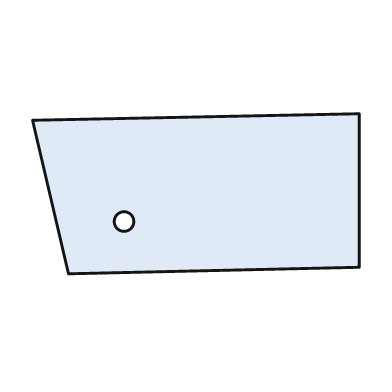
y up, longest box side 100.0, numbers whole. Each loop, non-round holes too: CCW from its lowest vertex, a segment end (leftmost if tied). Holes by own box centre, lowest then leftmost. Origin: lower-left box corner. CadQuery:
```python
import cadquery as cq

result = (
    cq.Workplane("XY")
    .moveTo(11.0, 0.0)
    .lineTo(100.0, 2.0)
    .lineTo(100.0, 49.0)
    .lineTo(0.0, 47.0)
    .close()
    .moveTo(28.0, 16.0)
    .circle(3.0)
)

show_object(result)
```